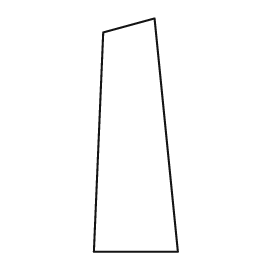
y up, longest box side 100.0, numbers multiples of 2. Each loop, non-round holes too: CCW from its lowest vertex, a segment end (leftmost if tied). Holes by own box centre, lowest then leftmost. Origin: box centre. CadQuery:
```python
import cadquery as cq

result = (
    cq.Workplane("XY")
    .moveTo(-18.0, -50.0)
    .lineTo(18.0, -50.0)
    .lineTo(8.0, 50.0)
    .lineTo(-14.0, 44.0)
    .close()
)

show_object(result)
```